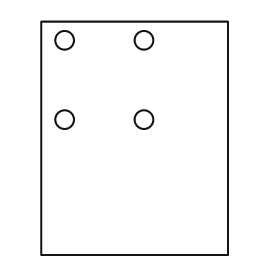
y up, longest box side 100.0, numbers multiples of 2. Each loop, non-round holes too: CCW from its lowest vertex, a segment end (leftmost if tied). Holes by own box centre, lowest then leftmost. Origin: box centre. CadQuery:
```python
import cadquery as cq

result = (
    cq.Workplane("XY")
    .moveTo(-40.0, -50.0)
    .lineTo(40.0, -50.0)
    .lineTo(40.0, 50.0)
    .lineTo(-40.0, 50.0)
    .close()
    .moveTo(-30.0, 8.0)
    .circle(4.0)
    .moveTo(4.0, 8.0)
    .circle(4.0)
    .moveTo(-30.0, 42.0)
    .circle(4.0)
    .moveTo(4.0, 42.0)
    .circle(4.0)
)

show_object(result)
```